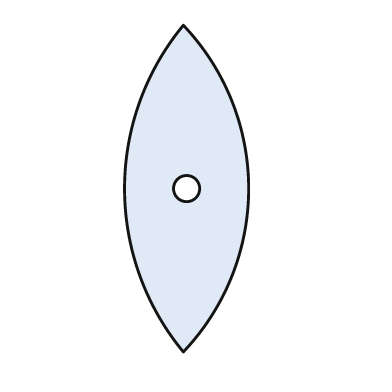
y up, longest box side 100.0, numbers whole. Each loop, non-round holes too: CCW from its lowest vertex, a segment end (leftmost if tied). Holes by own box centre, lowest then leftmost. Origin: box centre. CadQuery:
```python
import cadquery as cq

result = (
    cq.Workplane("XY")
    .moveTo(-1.0, -50.0)
    .threePointArc((19.0, 0.0), (-1.0, 50.0))
    .threePointArc((-19.0, 0.0), (-1.0, -50.0))
    .close()
    .moveTo(0.0, 0.0)
    .circle(4.0)
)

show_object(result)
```